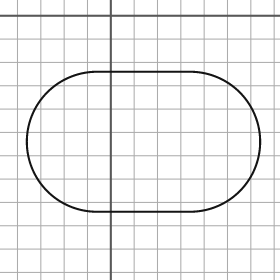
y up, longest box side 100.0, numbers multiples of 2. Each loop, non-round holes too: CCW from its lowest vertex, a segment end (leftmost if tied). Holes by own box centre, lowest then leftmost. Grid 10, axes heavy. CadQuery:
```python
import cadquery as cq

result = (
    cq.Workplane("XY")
    .moveTo(-6.0, -84.0)
    .lineTo(34.0, -84.0)
    .threePointArc((64.0, -54.0), (34.0, -24.0))
    .lineTo(-6.0, -24.0)
    .threePointArc((-36.0, -54.0), (-6.0, -84.0))
    .close()
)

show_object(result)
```